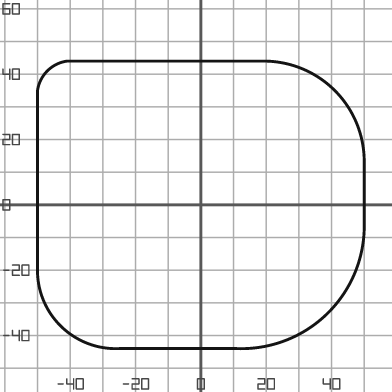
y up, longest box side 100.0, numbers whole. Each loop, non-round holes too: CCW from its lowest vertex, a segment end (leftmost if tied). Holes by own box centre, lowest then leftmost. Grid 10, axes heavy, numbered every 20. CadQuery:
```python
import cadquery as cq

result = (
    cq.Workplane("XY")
    .moveTo(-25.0, -44.0)
    .lineTo(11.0, -44.0)
    .threePointArc((39.0, -33.0), (50.0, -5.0))
    .lineTo(50.0, 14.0)
    .threePointArc((41.0, 35.0), (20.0, 44.0))
    .lineTo(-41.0, 44.0)
    .threePointArc((-47.0, 41.0), (-50.0, 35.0))
    .lineTo(-50.0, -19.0)
    .threePointArc((-43.0, -37.0), (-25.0, -44.0))
    .close()
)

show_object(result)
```